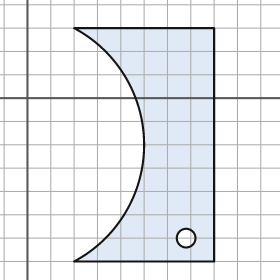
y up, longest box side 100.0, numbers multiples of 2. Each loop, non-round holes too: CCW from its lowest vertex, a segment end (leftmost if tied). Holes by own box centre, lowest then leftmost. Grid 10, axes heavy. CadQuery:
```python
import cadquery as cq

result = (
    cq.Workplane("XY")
    .moveTo(20.0, -70.0)
    .lineTo(80.0, -70.0)
    .lineTo(80.0, 30.0)
    .lineTo(20.0, 30.0)
    .threePointArc((50.0, -20.0), (20.0, -70.0))
    .close()
    .moveTo(68.0, -60.0)
    .circle(4.0)
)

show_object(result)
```